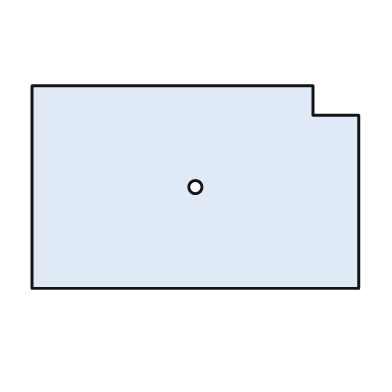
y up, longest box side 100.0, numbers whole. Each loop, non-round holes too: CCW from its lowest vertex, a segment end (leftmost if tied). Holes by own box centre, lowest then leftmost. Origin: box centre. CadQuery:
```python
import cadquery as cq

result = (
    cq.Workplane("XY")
    .moveTo(-50.0, -31.0)
    .lineTo(50.0, -31.0)
    .lineTo(50.0, 22.0)
    .lineTo(36.0, 22.0)
    .lineTo(36.0, 31.0)
    .lineTo(-50.0, 31.0)
    .close()
    .moveTo(0.0, 0.0)
    .circle(2.0)
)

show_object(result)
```